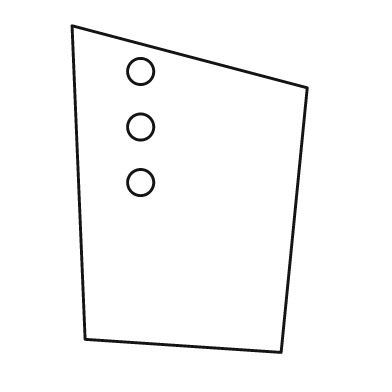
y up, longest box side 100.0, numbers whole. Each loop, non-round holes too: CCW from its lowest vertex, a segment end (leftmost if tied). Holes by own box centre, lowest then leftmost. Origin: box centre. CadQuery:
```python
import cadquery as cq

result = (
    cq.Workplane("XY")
    .moveTo(28.0, -50.0)
    .lineTo(36.0, 31.0)
    .lineTo(-36.0, 50.0)
    .lineTo(-32.0, -46.0)
    .close()
    .moveTo(-15.0, 2.0)
    .circle(4.0)
    .moveTo(-15.0, 19.0)
    .circle(4.0)
    .moveTo(-15.0, 36.0)
    .circle(4.0)
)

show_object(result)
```